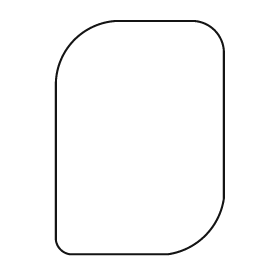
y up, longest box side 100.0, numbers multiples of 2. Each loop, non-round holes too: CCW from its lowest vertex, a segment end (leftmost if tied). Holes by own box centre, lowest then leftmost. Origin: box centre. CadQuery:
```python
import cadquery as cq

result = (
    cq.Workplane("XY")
    .moveTo(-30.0, -50.0)
    .lineTo(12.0, -50.0)
    .threePointArc((28.0, -42.0), (36.0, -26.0))
    .lineTo(36.0, 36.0)
    .threePointArc((32.0, 46.0), (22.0, 50.0))
    .lineTo(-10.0, 50.0)
    .threePointArc((-28.0, 42.0), (-36.0, 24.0))
    .lineTo(-36.0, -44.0)
    .threePointArc((-34.0, -48.0), (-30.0, -50.0))
    .close()
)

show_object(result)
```